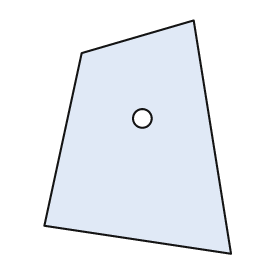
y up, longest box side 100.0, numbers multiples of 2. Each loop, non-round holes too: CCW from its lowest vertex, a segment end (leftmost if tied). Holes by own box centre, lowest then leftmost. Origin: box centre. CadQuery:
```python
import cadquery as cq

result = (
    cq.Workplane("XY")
    .moveTo(40.0, -50.0)
    .lineTo(24.0, 50.0)
    .lineTo(-24.0, 36.0)
    .lineTo(-40.0, -38.0)
    .close()
    .moveTo(2.0, 8.0)
    .circle(4.0)
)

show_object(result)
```